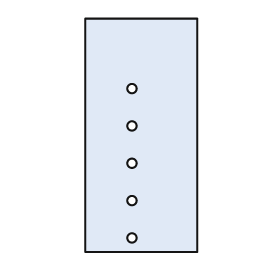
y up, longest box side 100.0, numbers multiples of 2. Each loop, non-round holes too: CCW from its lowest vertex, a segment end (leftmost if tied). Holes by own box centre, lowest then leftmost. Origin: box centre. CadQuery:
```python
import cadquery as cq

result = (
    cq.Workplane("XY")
    .moveTo(-24.0, -50.0)
    .lineTo(24.0, -50.0)
    .lineTo(24.0, 50.0)
    .lineTo(-24.0, 50.0)
    .close()
    .moveTo(-4.0, -44.0)
    .circle(2.0)
    .moveTo(-4.0, -28.0)
    .circle(2.0)
    .moveTo(-4.0, -12.0)
    .circle(2.0)
    .moveTo(-4.0, 4.0)
    .circle(2.0)
    .moveTo(-4.0, 20.0)
    .circle(2.0)
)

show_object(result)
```